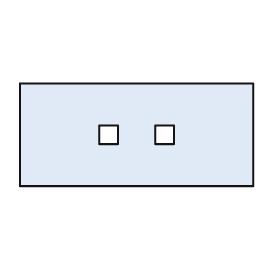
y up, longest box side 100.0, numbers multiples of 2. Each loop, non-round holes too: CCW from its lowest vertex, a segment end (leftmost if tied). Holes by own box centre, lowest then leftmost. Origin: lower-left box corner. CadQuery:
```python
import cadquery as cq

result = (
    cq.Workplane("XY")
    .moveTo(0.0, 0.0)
    .lineTo(100.0, 0.0)
    .lineTo(100.0, 44.0)
    .lineTo(0.0, 44.0)
    .close()
    .moveTo(34.0, 18.0)
    .lineTo(42.0, 18.0)
    .lineTo(42.0, 26.0)
    .lineTo(34.0, 26.0)
    .close()
    .moveTo(58.0, 18.0)
    .lineTo(66.0, 18.0)
    .lineTo(66.0, 26.0)
    .lineTo(58.0, 26.0)
    .close()
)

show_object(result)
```